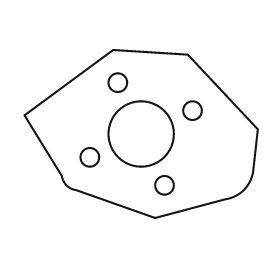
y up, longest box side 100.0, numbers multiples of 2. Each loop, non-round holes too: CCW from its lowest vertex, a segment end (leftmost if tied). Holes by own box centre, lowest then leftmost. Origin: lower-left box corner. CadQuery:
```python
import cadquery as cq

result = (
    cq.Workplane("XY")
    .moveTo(56.0, 0.0)
    .lineTo(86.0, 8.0)
    .threePointArc((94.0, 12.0), (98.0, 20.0))
    .lineTo(100.0, 38.0)
    .lineTo(70.0, 70.0)
    .lineTo(38.0, 72.0)
    .lineTo(0.0, 44.0)
    .lineTo(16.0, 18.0)
    .threePointArc((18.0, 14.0), (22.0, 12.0))
    .close()
    .moveTo(60.0, 14.0)
    .circle(4.0)
    .moveTo(28.0, 26.0)
    .circle(4.0)
    .moveTo(50.0, 36.0)
    .circle(14.0)
    .moveTo(72.0, 46.0)
    .circle(4.0)
    .moveTo(40.0, 58.0)
    .circle(4.0)
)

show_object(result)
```